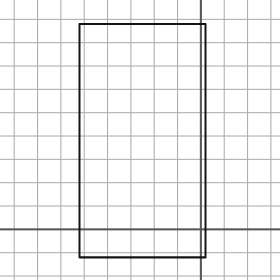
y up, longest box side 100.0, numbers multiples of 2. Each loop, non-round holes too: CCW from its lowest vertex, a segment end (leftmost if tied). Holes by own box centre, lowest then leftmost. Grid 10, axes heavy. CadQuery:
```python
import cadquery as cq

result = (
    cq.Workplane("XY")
    .moveTo(-52.0, -12.0)
    .lineTo(2.0, -12.0)
    .lineTo(2.0, 88.0)
    .lineTo(-52.0, 88.0)
    .close()
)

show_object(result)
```